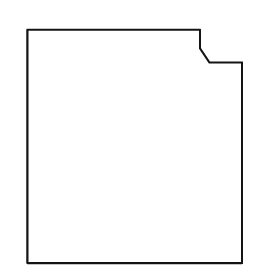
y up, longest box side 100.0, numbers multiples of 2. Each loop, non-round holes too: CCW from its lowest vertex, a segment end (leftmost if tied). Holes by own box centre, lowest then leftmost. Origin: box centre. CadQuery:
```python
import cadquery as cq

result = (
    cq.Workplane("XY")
    .moveTo(-46.0, -50.0)
    .lineTo(46.0, -50.0)
    .lineTo(46.0, 36.0)
    .lineTo(32.0, 36.0)
    .lineTo(28.0, 42.0)
    .lineTo(28.0, 50.0)
    .lineTo(-46.0, 50.0)
    .close()
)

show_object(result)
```